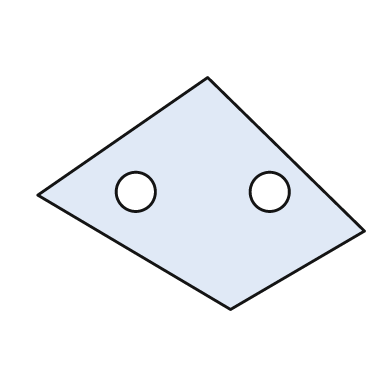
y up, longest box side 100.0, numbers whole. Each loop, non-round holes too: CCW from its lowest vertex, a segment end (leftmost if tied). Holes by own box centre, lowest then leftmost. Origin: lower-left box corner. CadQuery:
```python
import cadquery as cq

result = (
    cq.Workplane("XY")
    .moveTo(59.0, 0.0)
    .lineTo(100.0, 24.0)
    .lineTo(52.0, 71.0)
    .lineTo(0.0, 35.0)
    .close()
    .moveTo(30.0, 36.0)
    .circle(6.0)
    .moveTo(71.0, 36.0)
    .circle(6.0)
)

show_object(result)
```